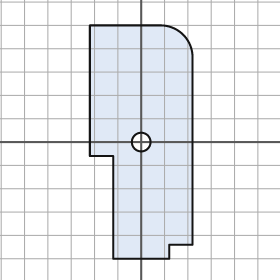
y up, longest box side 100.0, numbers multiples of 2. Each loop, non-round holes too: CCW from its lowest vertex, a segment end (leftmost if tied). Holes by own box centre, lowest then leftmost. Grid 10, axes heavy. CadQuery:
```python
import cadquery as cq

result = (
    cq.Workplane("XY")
    .moveTo(-12.0, -50.0)
    .lineTo(12.0, -50.0)
    .lineTo(12.0, -44.0)
    .lineTo(22.0, -44.0)
    .lineTo(22.0, 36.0)
    .threePointArc((18.0, 46.0), (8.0, 50.0))
    .lineTo(-22.0, 50.0)
    .lineTo(-22.0, -6.0)
    .lineTo(-12.0, -6.0)
    .close()
    .moveTo(0.0, 0.0)
    .circle(4.0)
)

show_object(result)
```